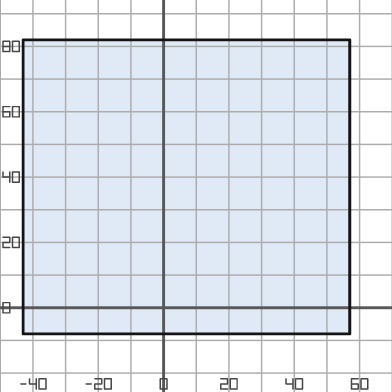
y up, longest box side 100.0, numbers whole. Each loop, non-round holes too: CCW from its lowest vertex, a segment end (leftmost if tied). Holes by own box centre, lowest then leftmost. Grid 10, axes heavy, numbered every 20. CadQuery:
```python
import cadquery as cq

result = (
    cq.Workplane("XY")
    .moveTo(-43.0, -8.0)
    .lineTo(57.0, -8.0)
    .lineTo(57.0, 82.0)
    .lineTo(-43.0, 82.0)
    .close()
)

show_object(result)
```